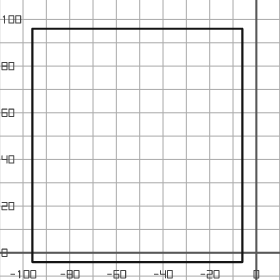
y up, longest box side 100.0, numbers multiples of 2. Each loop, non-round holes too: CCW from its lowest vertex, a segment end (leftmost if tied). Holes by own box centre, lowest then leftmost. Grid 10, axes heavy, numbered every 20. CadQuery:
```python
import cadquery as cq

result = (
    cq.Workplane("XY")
    .moveTo(-96.0, -4.0)
    .lineTo(-6.0, -4.0)
    .lineTo(-6.0, 96.0)
    .lineTo(-96.0, 96.0)
    .close()
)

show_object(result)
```